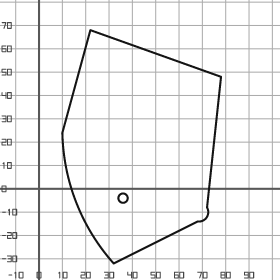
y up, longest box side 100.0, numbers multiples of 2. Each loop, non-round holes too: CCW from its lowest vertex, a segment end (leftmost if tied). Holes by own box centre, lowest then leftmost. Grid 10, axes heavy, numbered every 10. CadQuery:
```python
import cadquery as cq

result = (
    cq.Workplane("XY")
    .moveTo(32.0, -32.0)
    .lineTo(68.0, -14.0)
    .threePointArc((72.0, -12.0), (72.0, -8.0))
    .lineTo(78.0, 48.0)
    .lineTo(22.0, 68.0)
    .lineTo(10.0, 24.0)
    .threePointArc((16.0, -6.0), (32.0, -32.0))
    .close()
    .moveTo(36.0, -4.0)
    .circle(2.0)
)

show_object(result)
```